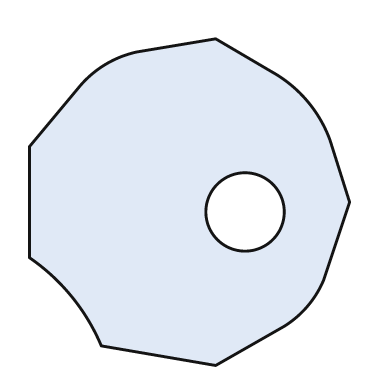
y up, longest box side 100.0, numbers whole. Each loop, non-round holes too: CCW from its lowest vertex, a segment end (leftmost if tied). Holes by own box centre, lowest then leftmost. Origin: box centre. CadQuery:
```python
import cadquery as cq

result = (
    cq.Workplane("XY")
    .moveTo(8.0, -50.0)
    .lineTo(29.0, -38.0)
    .threePointArc((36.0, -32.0), (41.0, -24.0))
    .lineTo(49.0, 0.0)
    .lineTo(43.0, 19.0)
    .threePointArc((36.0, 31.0), (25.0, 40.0))
    .lineTo(8.0, 50.0)
    .lineTo(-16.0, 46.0)
    .threePointArc((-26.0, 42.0), (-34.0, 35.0))
    .lineTo(-49.0, 17.0)
    .lineTo(-49.0, -17.0)
    .threePointArc((-36.0, -29.0), (-27.0, -44.0))
    .close()
    .moveTo(17.0, -3.0)
    .circle(12.0)
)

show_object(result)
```